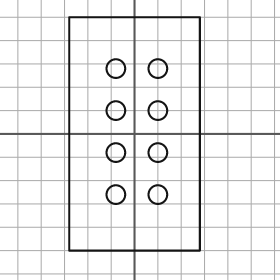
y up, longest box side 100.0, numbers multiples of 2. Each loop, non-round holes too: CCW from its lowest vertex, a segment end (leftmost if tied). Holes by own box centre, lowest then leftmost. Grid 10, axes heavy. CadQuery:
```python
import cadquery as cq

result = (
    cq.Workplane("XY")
    .moveTo(-28.0, -50.0)
    .lineTo(28.0, -50.0)
    .lineTo(28.0, 50.0)
    .lineTo(-28.0, 50.0)
    .close()
    .moveTo(-8.0, -26.0)
    .circle(4.0)
    .moveTo(10.0, -26.0)
    .circle(4.0)
    .moveTo(-8.0, -8.0)
    .circle(4.0)
    .moveTo(10.0, -8.0)
    .circle(4.0)
    .moveTo(-8.0, 10.0)
    .circle(4.0)
    .moveTo(10.0, 10.0)
    .circle(4.0)
    .moveTo(-8.0, 28.0)
    .circle(4.0)
    .moveTo(10.0, 28.0)
    .circle(4.0)
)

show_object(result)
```